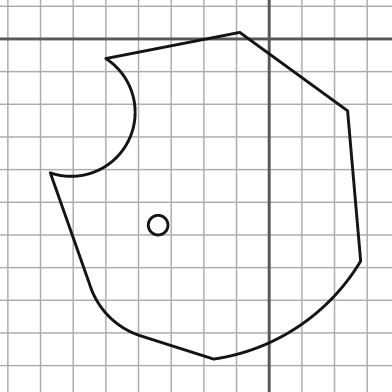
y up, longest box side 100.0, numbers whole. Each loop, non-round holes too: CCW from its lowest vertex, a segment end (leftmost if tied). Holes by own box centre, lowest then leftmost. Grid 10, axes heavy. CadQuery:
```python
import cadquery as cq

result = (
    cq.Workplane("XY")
    .moveTo(-17.0, -98.0)
    .threePointArc((9.0, -88.0), (28.0, -68.0))
    .lineTo(24.0, -22.0)
    .lineTo(-9.0, 2.0)
    .lineTo(-50.0, -6.0)
    .threePointArc((-43.0, -31.0), (-67.0, -41.0))
    .lineTo(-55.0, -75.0)
    .threePointArc((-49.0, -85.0), (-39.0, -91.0))
    .close()
    .moveTo(-34.0, -57.0)
    .circle(3.0)
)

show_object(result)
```